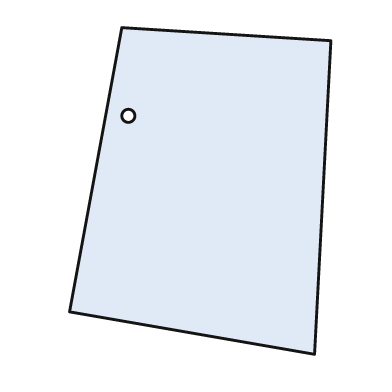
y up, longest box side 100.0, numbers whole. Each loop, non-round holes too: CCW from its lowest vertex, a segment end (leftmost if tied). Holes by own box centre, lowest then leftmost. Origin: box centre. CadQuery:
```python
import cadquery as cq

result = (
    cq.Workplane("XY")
    .moveTo(35.0, -50.0)
    .lineTo(40.0, 46.0)
    .lineTo(-24.0, 50.0)
    .lineTo(-40.0, -37.0)
    .close()
    .moveTo(-22.0, 23.0)
    .circle(2.0)
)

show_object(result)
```